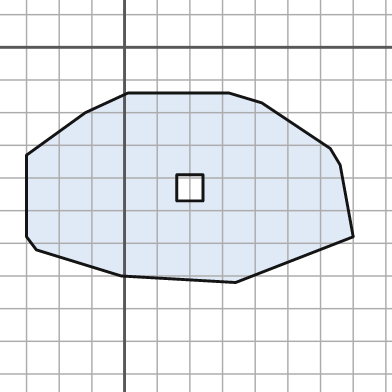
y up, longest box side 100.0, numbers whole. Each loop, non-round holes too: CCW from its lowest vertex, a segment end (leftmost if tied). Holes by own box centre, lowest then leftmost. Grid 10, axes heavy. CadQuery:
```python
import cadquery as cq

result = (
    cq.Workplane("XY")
    .moveTo(34.0, -72.0)
    .lineTo(70.0, -58.0)
    .lineTo(66.0, -36.0)
    .lineTo(63.0, -31.0)
    .lineTo(42.0, -17.0)
    .lineTo(32.0, -14.0)
    .lineTo(1.0, -14.0)
    .lineTo(-12.0, -20.0)
    .lineTo(-30.0, -33.0)
    .lineTo(-30.0, -58.0)
    .lineTo(-27.0, -62.0)
    .lineTo(-1.0, -70.0)
    .close()
    .moveTo(16.0, -47.0)
    .lineTo(24.0, -47.0)
    .lineTo(24.0, -39.0)
    .lineTo(16.0, -39.0)
    .close()
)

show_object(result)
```